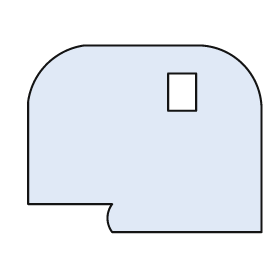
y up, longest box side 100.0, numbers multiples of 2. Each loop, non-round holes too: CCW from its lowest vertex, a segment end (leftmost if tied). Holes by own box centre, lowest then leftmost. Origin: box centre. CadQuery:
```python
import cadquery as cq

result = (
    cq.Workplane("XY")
    .moveTo(-14.0, -40.0)
    .lineTo(50.0, -40.0)
    .lineTo(50.0, 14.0)
    .threePointArc((42.0, 32.0), (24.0, 40.0))
    .lineTo(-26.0, 40.0)
    .threePointArc((-42.0, 32.0), (-50.0, 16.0))
    .lineTo(-50.0, -28.0)
    .lineTo(-14.0, -28.0)
    .threePointArc((-16.0, -34.0), (-14.0, -40.0))
    .close()
    .moveTo(10.0, 12.0)
    .lineTo(22.0, 12.0)
    .lineTo(22.0, 28.0)
    .lineTo(10.0, 28.0)
    .close()
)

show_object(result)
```